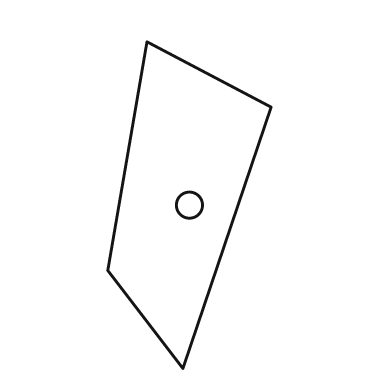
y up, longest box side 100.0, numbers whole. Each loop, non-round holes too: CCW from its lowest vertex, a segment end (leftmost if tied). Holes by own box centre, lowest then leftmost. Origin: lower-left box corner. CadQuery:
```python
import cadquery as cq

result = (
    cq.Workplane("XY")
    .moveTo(23.0, 0.0)
    .lineTo(50.0, 80.0)
    .lineTo(12.0, 100.0)
    .lineTo(0.0, 30.0)
    .close()
    .moveTo(25.0, 50.0)
    .circle(4.0)
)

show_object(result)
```